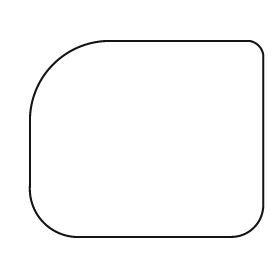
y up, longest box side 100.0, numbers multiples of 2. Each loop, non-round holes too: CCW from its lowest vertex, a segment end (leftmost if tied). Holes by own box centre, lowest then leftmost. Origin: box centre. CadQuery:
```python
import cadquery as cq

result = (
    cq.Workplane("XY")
    .moveTo(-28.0, -42.0)
    .lineTo(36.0, -42.0)
    .threePointArc((46.0, -38.0), (50.0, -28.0))
    .lineTo(50.0, 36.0)
    .threePointArc((48.0, 40.0), (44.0, 42.0))
    .lineTo(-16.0, 42.0)
    .threePointArc((-40.0, 32.0), (-50.0, 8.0))
    .lineTo(-50.0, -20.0)
    .threePointArc((-44.0, -36.0), (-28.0, -42.0))
    .close()
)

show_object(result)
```